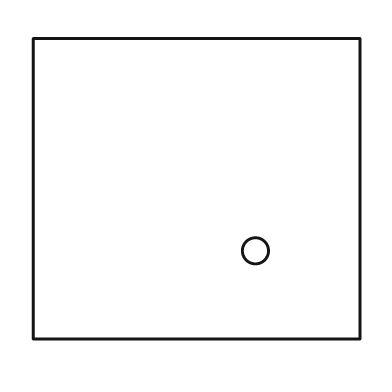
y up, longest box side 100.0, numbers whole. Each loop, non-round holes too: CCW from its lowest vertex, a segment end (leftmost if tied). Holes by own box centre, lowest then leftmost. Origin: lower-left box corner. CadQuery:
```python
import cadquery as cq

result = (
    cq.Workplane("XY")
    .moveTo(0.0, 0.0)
    .lineTo(100.0, 0.0)
    .lineTo(100.0, 92.0)
    .lineTo(0.0, 92.0)
    .close()
    .moveTo(68.0, 27.0)
    .circle(4.0)
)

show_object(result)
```